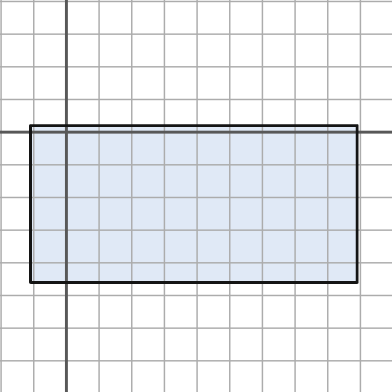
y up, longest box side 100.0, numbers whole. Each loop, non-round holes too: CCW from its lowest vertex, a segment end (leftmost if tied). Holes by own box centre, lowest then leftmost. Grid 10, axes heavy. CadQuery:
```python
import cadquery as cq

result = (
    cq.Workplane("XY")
    .moveTo(-11.0, -46.0)
    .lineTo(89.0, -46.0)
    .lineTo(89.0, 2.0)
    .lineTo(-11.0, 2.0)
    .close()
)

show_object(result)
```